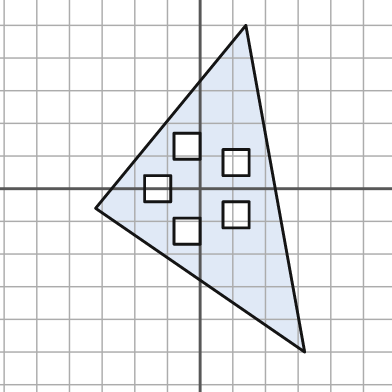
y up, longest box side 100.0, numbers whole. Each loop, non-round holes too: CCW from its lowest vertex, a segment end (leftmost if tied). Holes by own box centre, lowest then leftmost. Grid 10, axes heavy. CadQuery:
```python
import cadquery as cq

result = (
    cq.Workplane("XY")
    .moveTo(32.0, -50.0)
    .lineTo(14.0, 50.0)
    .lineTo(-32.0, -6.0)
    .close()
    .moveTo(-8.0, -17.0)
    .lineTo(0.0, -17.0)
    .lineTo(0.0, -9.0)
    .lineTo(-8.0, -9.0)
    .close()
    .moveTo(7.0, -12.0)
    .lineTo(15.0, -12.0)
    .lineTo(15.0, -4.0)
    .lineTo(7.0, -4.0)
    .close()
    .moveTo(-17.0, -4.0)
    .lineTo(-9.0, -4.0)
    .lineTo(-9.0, 4.0)
    .lineTo(-17.0, 4.0)
    .close()
    .moveTo(7.0, 4.0)
    .lineTo(15.0, 4.0)
    .lineTo(15.0, 12.0)
    .lineTo(7.0, 12.0)
    .close()
    .moveTo(-8.0, 9.0)
    .lineTo(0.0, 9.0)
    .lineTo(0.0, 17.0)
    .lineTo(-8.0, 17.0)
    .close()
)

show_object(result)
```